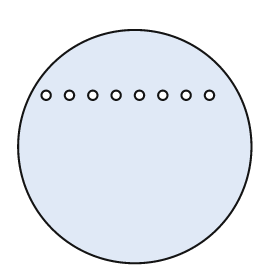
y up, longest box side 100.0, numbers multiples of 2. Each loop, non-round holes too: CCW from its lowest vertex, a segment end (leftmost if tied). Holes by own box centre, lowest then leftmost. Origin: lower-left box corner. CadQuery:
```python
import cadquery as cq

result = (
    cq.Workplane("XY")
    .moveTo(50.0, 50.0)
    .circle(50.0)
    .moveTo(12.0, 72.0)
    .circle(2.0)
    .moveTo(22.0, 72.0)
    .circle(2.0)
    .moveTo(32.0, 72.0)
    .circle(2.0)
    .moveTo(42.0, 72.0)
    .circle(2.0)
    .moveTo(52.0, 72.0)
    .circle(2.0)
    .moveTo(62.0, 72.0)
    .circle(2.0)
    .moveTo(72.0, 72.0)
    .circle(2.0)
    .moveTo(82.0, 72.0)
    .circle(2.0)
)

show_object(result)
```